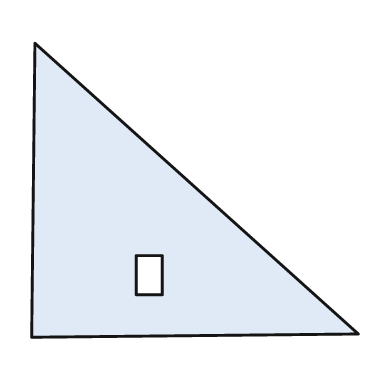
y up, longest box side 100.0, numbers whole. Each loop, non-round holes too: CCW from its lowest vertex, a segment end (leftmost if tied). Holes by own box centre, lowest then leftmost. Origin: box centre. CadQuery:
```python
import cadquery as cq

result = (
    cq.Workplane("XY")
    .moveTo(-50.0, -45.0)
    .lineTo(50.0, -44.0)
    .lineTo(-49.0, 45.0)
    .close()
    .moveTo(-18.0, -32.0)
    .lineTo(-10.0, -32.0)
    .lineTo(-10.0, -20.0)
    .lineTo(-18.0, -20.0)
    .close()
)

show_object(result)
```